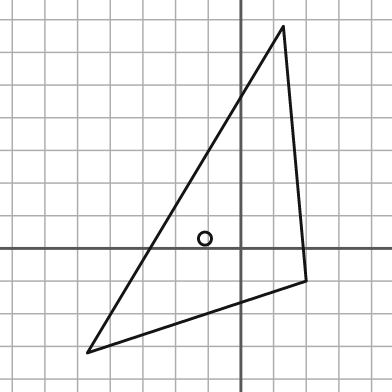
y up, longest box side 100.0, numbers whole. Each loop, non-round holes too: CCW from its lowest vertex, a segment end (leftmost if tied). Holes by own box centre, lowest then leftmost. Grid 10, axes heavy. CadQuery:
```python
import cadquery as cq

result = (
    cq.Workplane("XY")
    .moveTo(-47.0, -32.0)
    .lineTo(20.0, -10.0)
    .lineTo(13.0, 68.0)
    .close()
    .moveTo(-11.0, 3.0)
    .circle(2.0)
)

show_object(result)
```